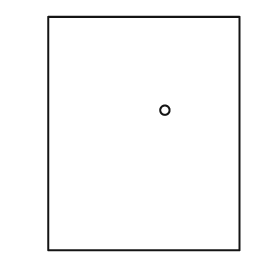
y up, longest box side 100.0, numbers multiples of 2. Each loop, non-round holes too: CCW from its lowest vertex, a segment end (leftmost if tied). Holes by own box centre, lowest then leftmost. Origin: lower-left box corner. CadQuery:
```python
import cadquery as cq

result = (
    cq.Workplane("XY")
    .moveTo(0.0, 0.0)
    .lineTo(82.0, 0.0)
    .lineTo(82.0, 100.0)
    .lineTo(0.0, 100.0)
    .close()
    .moveTo(50.0, 60.0)
    .circle(2.0)
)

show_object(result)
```